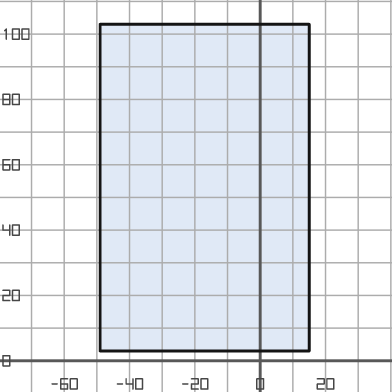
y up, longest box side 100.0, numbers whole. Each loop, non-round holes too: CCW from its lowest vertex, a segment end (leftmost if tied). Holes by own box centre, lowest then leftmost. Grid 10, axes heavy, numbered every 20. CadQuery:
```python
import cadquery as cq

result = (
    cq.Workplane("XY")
    .moveTo(-49.0, 3.0)
    .lineTo(15.0, 3.0)
    .lineTo(15.0, 103.0)
    .lineTo(-49.0, 103.0)
    .close()
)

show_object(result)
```